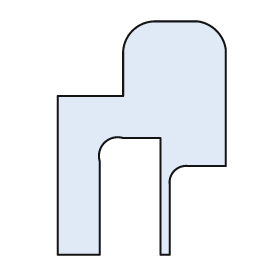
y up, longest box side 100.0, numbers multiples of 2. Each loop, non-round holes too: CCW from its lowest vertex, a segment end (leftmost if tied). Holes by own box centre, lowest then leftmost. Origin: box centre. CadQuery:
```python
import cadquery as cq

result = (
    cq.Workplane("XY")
    .moveTo(-36.0, -50.0)
    .lineTo(-18.0, -50.0)
    .lineTo(-18.0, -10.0)
    .threePointArc((-16.0, -2.0), (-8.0, 0.0))
    .lineTo(8.0, 0.0)
    .lineTo(8.0, -50.0)
    .lineTo(12.0, -50.0)
    .lineTo(12.0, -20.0)
    .threePointArc((14.0, -14.0), (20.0, -12.0))
    .lineTo(36.0, -12.0)
    .lineTo(36.0, 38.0)
    .threePointArc((32.0, 46.0), (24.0, 50.0))
    .lineTo(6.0, 50.0)
    .threePointArc((-4.0, 46.0), (-8.0, 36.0))
    .lineTo(-8.0, 18.0)
    .lineTo(-36.0, 18.0)
    .close()
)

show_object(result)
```